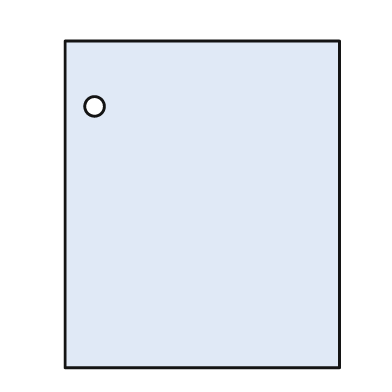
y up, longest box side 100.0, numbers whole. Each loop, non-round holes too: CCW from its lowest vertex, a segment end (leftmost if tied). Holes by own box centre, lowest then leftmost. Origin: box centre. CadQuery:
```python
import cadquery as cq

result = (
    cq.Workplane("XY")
    .moveTo(-42.0, -50.0)
    .lineTo(42.0, -50.0)
    .lineTo(42.0, 50.0)
    .lineTo(-42.0, 50.0)
    .close()
    .moveTo(-33.0, 30.0)
    .circle(3.0)
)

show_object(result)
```